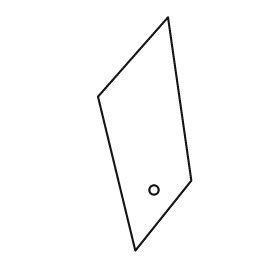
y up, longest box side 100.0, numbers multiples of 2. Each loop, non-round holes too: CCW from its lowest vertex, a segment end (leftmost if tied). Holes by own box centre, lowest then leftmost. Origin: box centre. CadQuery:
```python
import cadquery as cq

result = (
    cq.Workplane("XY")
    .moveTo(-4.0, -50.0)
    .lineTo(20.0, -20.0)
    .lineTo(10.0, 50.0)
    .lineTo(-20.0, 16.0)
    .close()
    .moveTo(4.0, -24.0)
    .circle(2.0)
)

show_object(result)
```